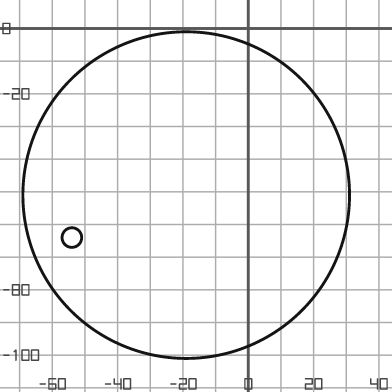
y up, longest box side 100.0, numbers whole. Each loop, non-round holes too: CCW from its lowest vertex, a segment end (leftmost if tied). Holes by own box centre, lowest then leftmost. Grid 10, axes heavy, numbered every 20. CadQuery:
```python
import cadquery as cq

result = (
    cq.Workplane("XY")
    .moveTo(-19.0, -51.0)
    .circle(50.0)
    .moveTo(-54.0, -64.0)
    .circle(3.0)
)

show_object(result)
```